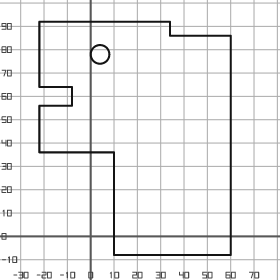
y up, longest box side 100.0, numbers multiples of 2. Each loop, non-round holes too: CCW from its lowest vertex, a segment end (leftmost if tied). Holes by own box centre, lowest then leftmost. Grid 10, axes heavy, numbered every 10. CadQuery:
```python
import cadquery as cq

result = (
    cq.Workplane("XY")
    .moveTo(10.0, -8.0)
    .lineTo(60.0, -8.0)
    .lineTo(60.0, 86.0)
    .lineTo(34.0, 86.0)
    .lineTo(34.0, 92.0)
    .lineTo(-22.0, 92.0)
    .lineTo(-22.0, 64.0)
    .lineTo(-8.0, 64.0)
    .lineTo(-8.0, 56.0)
    .lineTo(-22.0, 56.0)
    .lineTo(-22.0, 36.0)
    .lineTo(10.0, 36.0)
    .close()
    .moveTo(4.0, 78.0)
    .circle(4.0)
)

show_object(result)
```